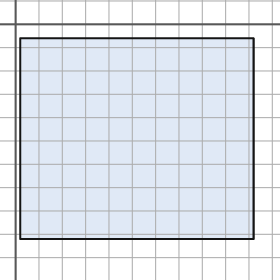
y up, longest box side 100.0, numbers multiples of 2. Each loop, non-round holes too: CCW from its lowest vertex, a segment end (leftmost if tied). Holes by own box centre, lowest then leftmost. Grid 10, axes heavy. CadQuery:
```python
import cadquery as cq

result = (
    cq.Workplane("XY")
    .moveTo(2.0, -92.0)
    .lineTo(102.0, -92.0)
    .lineTo(102.0, -6.0)
    .lineTo(2.0, -6.0)
    .close()
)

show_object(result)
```